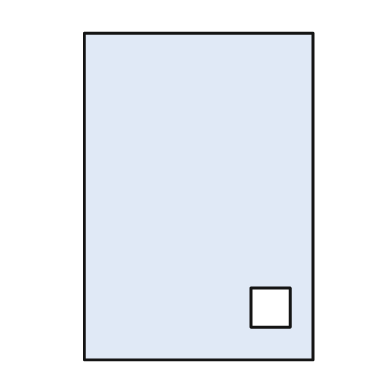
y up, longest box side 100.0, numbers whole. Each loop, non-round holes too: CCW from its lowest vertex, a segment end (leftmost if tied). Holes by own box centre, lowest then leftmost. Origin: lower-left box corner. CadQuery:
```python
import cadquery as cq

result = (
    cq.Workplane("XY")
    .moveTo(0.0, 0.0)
    .lineTo(70.0, 0.0)
    .lineTo(70.0, 100.0)
    .lineTo(0.0, 100.0)
    .close()
    .moveTo(51.0, 10.0)
    .lineTo(63.0, 10.0)
    .lineTo(63.0, 22.0)
    .lineTo(51.0, 22.0)
    .close()
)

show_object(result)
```